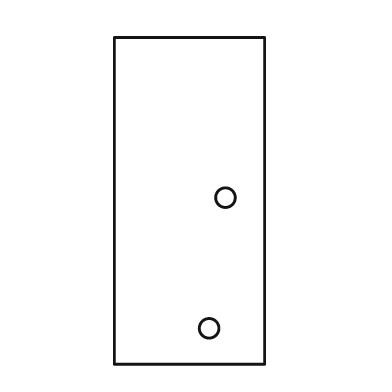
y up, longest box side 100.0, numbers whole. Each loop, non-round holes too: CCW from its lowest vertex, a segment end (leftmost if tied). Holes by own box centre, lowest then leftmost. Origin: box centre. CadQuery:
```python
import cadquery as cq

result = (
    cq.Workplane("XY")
    .moveTo(-23.0, -50.0)
    .lineTo(23.0, -50.0)
    .lineTo(23.0, 50.0)
    .lineTo(-23.0, 50.0)
    .close()
    .moveTo(6.0, -39.0)
    .circle(3.0)
    .moveTo(11.0, 1.0)
    .circle(3.0)
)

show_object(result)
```